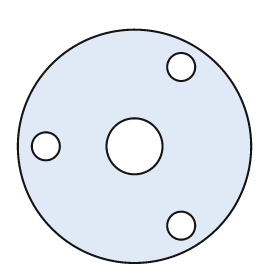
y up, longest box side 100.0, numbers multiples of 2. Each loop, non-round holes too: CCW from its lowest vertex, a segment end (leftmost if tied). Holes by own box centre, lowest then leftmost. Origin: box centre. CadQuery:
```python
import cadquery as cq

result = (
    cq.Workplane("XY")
    .moveTo(0.0, 0.0)
    .circle(50.0)
    .moveTo(20.0, -34.0)
    .circle(6.0)
    .moveTo(-38.0, 0.0)
    .circle(6.0)
    .moveTo(0.0, 0.0)
    .circle(12.0)
    .moveTo(20.0, 34.0)
    .circle(6.0)
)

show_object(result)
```